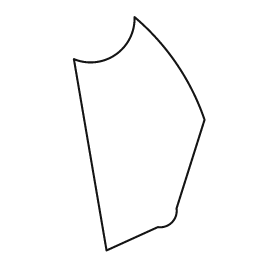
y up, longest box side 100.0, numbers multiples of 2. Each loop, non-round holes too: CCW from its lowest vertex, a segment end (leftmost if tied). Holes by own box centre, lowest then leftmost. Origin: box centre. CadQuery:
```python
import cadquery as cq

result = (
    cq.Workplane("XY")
    .moveTo(-14.0, -50.0)
    .lineTo(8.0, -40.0)
    .threePointArc((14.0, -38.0), (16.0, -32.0))
    .lineTo(28.0, 6.0)
    .threePointArc((16.0, 30.0), (-2.0, 50.0))
    .threePointArc((-10.0, 34.0), (-28.0, 32.0))
    .close()
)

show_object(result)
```